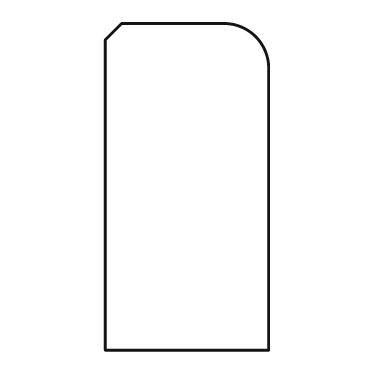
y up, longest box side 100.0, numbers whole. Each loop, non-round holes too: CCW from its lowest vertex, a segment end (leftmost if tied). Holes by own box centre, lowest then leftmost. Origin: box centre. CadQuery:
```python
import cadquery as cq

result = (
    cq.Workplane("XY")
    .moveTo(-25.0, -50.0)
    .lineTo(25.0, -50.0)
    .lineTo(25.0, 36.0)
    .threePointArc((21.0, 46.0), (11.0, 50.0))
    .lineTo(-20.0, 50.0)
    .lineTo(-25.0, 45.0)
    .close()
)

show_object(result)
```